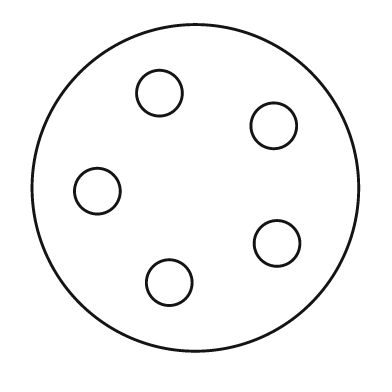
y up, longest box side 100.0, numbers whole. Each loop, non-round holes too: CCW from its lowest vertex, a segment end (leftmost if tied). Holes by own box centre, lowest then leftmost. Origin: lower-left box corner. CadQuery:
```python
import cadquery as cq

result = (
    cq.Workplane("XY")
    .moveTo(50.0, 50.0)
    .circle(50.0)
    .moveTo(42.0, 21.0)
    .circle(7.0)
    .moveTo(75.0, 33.0)
    .circle(7.0)
    .moveTo(20.0, 49.0)
    .circle(7.0)
    .moveTo(74.0, 69.0)
    .circle(7.0)
    .moveTo(39.0, 79.0)
    .circle(7.0)
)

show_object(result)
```